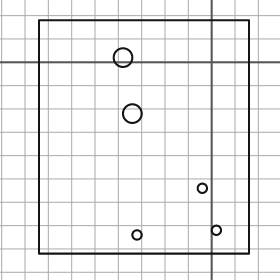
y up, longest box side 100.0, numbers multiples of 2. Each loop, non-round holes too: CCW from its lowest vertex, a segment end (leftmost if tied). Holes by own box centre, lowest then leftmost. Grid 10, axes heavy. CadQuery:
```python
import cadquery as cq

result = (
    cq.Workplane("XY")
    .moveTo(-74.0, -82.0)
    .lineTo(16.0, -82.0)
    .lineTo(16.0, 18.0)
    .lineTo(-74.0, 18.0)
    .close()
    .moveTo(-32.0, -74.0)
    .circle(2.0)
    .moveTo(2.0, -72.0)
    .circle(2.0)
    .moveTo(-4.0, -54.0)
    .circle(2.0)
    .moveTo(-34.0, -22.0)
    .circle(4.0)
    .moveTo(-38.0, 2.0)
    .circle(4.0)
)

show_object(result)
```